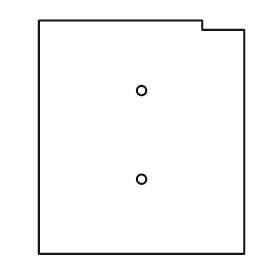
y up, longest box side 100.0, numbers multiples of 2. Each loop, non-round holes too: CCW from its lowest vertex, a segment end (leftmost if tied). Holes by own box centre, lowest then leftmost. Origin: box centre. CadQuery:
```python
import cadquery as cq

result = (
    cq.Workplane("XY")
    .moveTo(-44.0, -50.0)
    .lineTo(44.0, -50.0)
    .lineTo(44.0, 46.0)
    .lineTo(26.0, 46.0)
    .lineTo(26.0, 50.0)
    .lineTo(-44.0, 50.0)
    .close()
    .moveTo(0.0, -18.0)
    .circle(2.0)
    .moveTo(0.0, 20.0)
    .circle(2.0)
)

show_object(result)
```